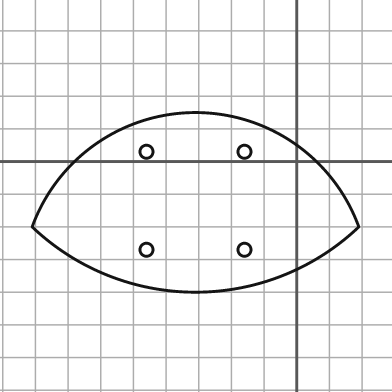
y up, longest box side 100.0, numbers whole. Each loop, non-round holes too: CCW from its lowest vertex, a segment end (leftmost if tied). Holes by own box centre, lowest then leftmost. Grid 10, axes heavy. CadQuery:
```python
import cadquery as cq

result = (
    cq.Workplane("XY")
    .moveTo(-81.0, -20.0)
    .threePointArc((-31.0, -40.0), (19.0, -20.0))
    .threePointArc((-31.0, 15.0), (-81.0, -20.0))
    .close()
    .moveTo(-46.0, -27.0)
    .circle(2.0)
    .moveTo(-16.0, -27.0)
    .circle(2.0)
    .moveTo(-46.0, 3.0)
    .circle(2.0)
    .moveTo(-16.0, 3.0)
    .circle(2.0)
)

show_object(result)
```